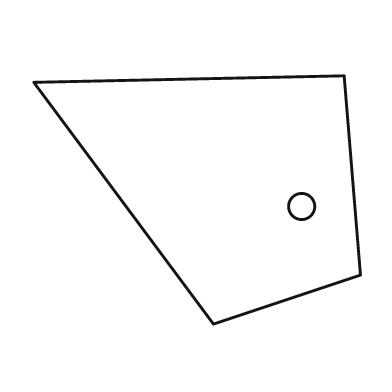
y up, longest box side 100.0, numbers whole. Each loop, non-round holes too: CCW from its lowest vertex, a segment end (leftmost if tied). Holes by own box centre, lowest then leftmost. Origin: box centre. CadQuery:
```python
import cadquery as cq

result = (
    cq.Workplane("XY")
    .moveTo(5.0, -38.0)
    .lineTo(50.0, -23.0)
    .lineTo(45.0, 38.0)
    .lineTo(-50.0, 36.0)
    .close()
    .moveTo(32.0, -2.0)
    .circle(4.0)
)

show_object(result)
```